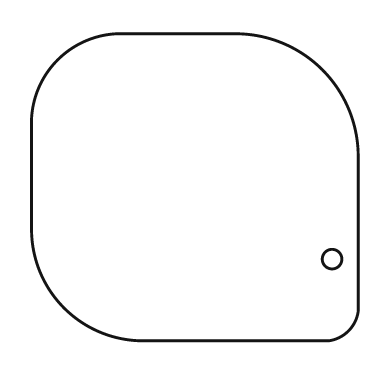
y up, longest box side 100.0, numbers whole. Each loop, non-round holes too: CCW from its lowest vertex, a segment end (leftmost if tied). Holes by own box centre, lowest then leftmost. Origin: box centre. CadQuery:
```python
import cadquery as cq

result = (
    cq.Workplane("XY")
    .moveTo(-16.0, -47.0)
    .lineTo(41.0, -47.0)
    .threePointArc((47.0, -44.0), (50.0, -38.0))
    .lineTo(50.0, 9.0)
    .threePointArc((39.0, 36.0), (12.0, 47.0))
    .lineTo(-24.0, 47.0)
    .threePointArc((-42.0, 39.0), (-50.0, 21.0))
    .lineTo(-50.0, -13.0)
    .threePointArc((-40.0, -37.0), (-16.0, -47.0))
    .close()
    .moveTo(42.0, -22.0)
    .circle(3.0)
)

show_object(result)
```